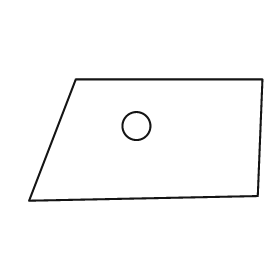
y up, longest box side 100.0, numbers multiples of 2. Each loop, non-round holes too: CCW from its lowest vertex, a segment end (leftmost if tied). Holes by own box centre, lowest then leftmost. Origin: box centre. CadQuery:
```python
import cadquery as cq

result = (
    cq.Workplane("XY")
    .moveTo(-50.0, -26.0)
    .lineTo(48.0, -24.0)
    .lineTo(50.0, 26.0)
    .lineTo(-30.0, 26.0)
    .close()
    .moveTo(-4.0, 6.0)
    .circle(6.0)
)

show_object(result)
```